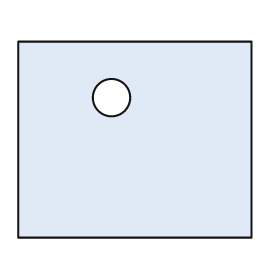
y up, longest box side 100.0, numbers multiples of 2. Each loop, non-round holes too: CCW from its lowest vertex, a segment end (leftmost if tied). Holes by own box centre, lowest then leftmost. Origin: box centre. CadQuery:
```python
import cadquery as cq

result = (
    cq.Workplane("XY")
    .moveTo(-50.0, -42.0)
    .lineTo(50.0, -42.0)
    .lineTo(50.0, 42.0)
    .lineTo(-50.0, 42.0)
    .close()
    .moveTo(-10.0, 18.0)
    .circle(8.0)
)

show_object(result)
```